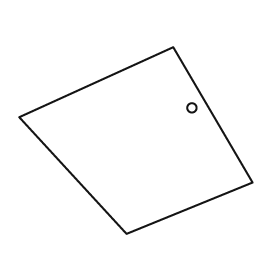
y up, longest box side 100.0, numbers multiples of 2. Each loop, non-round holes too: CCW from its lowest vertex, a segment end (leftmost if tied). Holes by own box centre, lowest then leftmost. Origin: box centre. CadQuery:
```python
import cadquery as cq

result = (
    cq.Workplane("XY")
    .moveTo(-4.0, -40.0)
    .lineTo(50.0, -18.0)
    .lineTo(16.0, 40.0)
    .lineTo(-50.0, 10.0)
    .close()
    .moveTo(24.0, 14.0)
    .circle(2.0)
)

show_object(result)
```